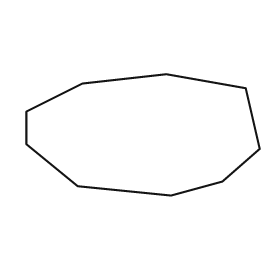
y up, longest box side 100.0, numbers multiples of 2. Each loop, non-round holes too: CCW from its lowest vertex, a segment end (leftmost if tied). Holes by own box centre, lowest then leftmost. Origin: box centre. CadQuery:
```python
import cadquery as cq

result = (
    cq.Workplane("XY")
    .moveTo(12.0, -26.0)
    .lineTo(34.0, -20.0)
    .lineTo(50.0, -6.0)
    .lineTo(44.0, 20.0)
    .lineTo(10.0, 26.0)
    .lineTo(-26.0, 22.0)
    .lineTo(-50.0, 10.0)
    .lineTo(-50.0, -4.0)
    .lineTo(-28.0, -22.0)
    .close()
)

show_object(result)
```